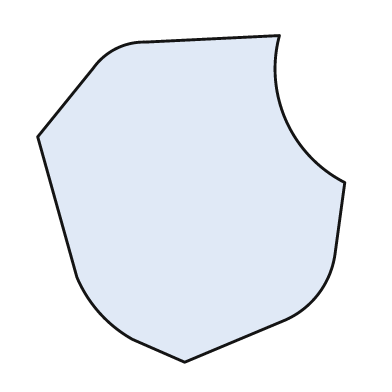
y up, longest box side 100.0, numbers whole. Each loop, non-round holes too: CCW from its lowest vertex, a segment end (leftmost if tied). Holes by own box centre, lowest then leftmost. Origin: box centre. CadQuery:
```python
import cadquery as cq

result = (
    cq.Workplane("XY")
    .moveTo(-2.0, -50.0)
    .lineTo(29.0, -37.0)
    .threePointArc((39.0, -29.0), (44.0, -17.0))
    .lineTo(47.0, 5.0)
    .threePointArc((29.0, 24.0), (27.0, 50.0))
    .lineTo(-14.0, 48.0)
    .threePointArc((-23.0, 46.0), (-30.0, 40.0))
    .lineTo(-47.0, 19.0)
    .lineTo(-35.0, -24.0)
    .threePointArc((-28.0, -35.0), (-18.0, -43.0))
    .close()
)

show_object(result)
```